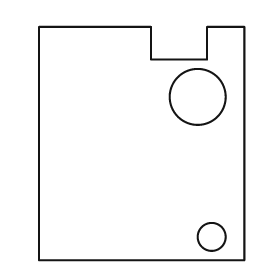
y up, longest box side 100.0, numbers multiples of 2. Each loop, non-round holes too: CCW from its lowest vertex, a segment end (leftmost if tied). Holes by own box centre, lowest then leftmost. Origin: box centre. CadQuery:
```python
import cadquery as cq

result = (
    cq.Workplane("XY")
    .moveTo(-44.0, -50.0)
    .lineTo(44.0, -50.0)
    .lineTo(44.0, 50.0)
    .lineTo(28.0, 50.0)
    .lineTo(28.0, 36.0)
    .lineTo(4.0, 36.0)
    .lineTo(4.0, 50.0)
    .lineTo(-44.0, 50.0)
    .close()
    .moveTo(30.0, -40.0)
    .circle(6.0)
    .moveTo(24.0, 20.0)
    .circle(12.0)
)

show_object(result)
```